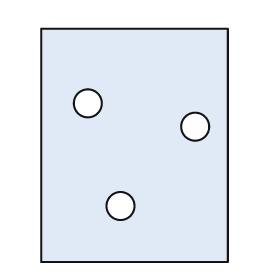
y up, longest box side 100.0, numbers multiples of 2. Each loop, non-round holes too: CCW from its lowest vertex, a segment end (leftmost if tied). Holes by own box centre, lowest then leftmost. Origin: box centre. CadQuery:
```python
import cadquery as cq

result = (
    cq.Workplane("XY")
    .moveTo(-40.0, -50.0)
    .lineTo(40.0, -50.0)
    .lineTo(40.0, 50.0)
    .lineTo(-40.0, 50.0)
    .close()
    .moveTo(-6.0, -26.0)
    .circle(6.0)
    .moveTo(26.0, 8.0)
    .circle(6.0)
    .moveTo(-20.0, 18.0)
    .circle(6.0)
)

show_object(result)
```